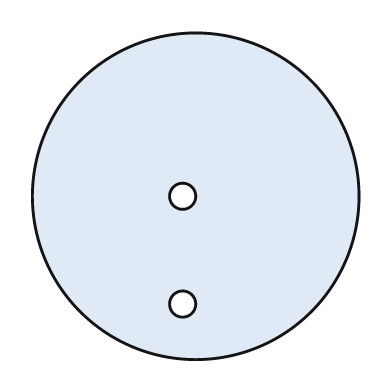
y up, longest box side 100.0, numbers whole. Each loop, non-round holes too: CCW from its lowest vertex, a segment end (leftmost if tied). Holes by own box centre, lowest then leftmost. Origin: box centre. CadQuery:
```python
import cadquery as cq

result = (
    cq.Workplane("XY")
    .moveTo(0.0, 0.0)
    .circle(50.0)
    .moveTo(-4.0, -33.0)
    .circle(4.0)
    .moveTo(-4.0, 0.0)
    .circle(4.0)
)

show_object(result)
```